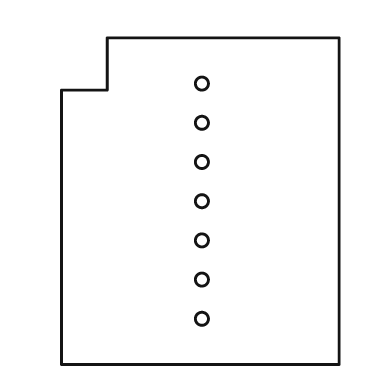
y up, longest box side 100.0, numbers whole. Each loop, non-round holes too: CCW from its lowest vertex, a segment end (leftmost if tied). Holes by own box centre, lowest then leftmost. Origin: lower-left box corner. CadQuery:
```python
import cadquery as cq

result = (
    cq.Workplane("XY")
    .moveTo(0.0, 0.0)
    .lineTo(85.0, 0.0)
    .lineTo(85.0, 100.0)
    .lineTo(14.0, 100.0)
    .lineTo(14.0, 84.0)
    .lineTo(0.0, 84.0)
    .close()
    .moveTo(43.0, 14.0)
    .circle(2.0)
    .moveTo(43.0, 26.0)
    .circle(2.0)
    .moveTo(43.0, 38.0)
    .circle(2.0)
    .moveTo(43.0, 50.0)
    .circle(2.0)
    .moveTo(43.0, 62.0)
    .circle(2.0)
    .moveTo(43.0, 74.0)
    .circle(2.0)
    .moveTo(43.0, 86.0)
    .circle(2.0)
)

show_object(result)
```